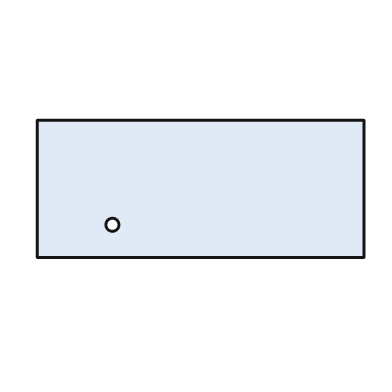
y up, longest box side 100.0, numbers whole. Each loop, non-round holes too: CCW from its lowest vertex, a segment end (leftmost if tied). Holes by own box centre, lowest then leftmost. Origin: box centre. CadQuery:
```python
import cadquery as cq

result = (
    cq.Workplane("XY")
    .moveTo(-50.0, -21.0)
    .lineTo(50.0, -21.0)
    .lineTo(50.0, 21.0)
    .lineTo(-50.0, 21.0)
    .close()
    .moveTo(-27.0, -11.0)
    .circle(2.0)
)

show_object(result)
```